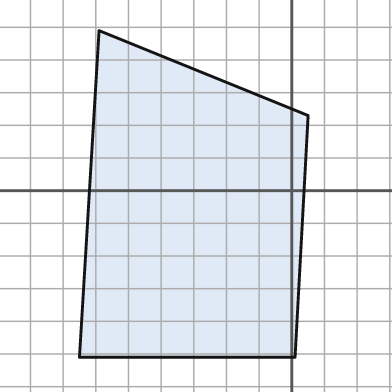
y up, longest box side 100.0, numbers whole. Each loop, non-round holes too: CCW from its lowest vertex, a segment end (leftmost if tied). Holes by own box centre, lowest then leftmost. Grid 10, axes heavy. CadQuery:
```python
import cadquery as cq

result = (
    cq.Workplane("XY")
    .moveTo(-65.0, -51.0)
    .lineTo(1.0, -51.0)
    .lineTo(5.0, 23.0)
    .lineTo(-59.0, 49.0)
    .close()
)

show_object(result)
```